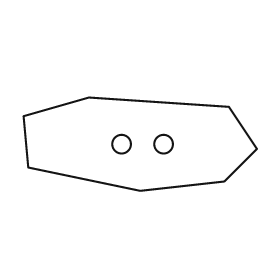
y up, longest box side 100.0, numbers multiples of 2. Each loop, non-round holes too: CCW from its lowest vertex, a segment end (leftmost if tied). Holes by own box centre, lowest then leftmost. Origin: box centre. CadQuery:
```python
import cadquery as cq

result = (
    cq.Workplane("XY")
    .moveTo(0.0, -20.0)
    .lineTo(36.0, -16.0)
    .lineTo(50.0, -2.0)
    .lineTo(38.0, 16.0)
    .lineTo(-22.0, 20.0)
    .lineTo(-50.0, 12.0)
    .lineTo(-48.0, -10.0)
    .close()
    .moveTo(-8.0, 0.0)
    .circle(4.0)
    .moveTo(10.0, 0.0)
    .circle(4.0)
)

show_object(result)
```